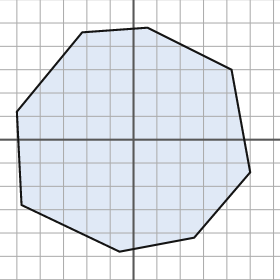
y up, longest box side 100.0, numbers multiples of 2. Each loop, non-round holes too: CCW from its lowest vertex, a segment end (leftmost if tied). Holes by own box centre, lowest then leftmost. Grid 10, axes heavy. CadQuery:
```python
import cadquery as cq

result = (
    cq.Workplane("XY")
    .moveTo(-6.0, -48.0)
    .lineTo(26.0, -42.0)
    .lineTo(50.0, -14.0)
    .lineTo(42.0, 30.0)
    .lineTo(6.0, 48.0)
    .lineTo(-22.0, 46.0)
    .lineTo(-50.0, 12.0)
    .lineTo(-48.0, -28.0)
    .close()
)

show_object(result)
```